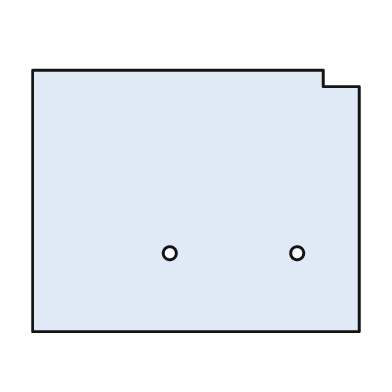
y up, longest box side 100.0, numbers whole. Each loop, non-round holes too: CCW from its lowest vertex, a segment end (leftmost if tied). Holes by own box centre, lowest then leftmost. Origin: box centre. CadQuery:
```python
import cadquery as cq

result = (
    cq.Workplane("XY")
    .moveTo(-50.0, -40.0)
    .lineTo(50.0, -40.0)
    .lineTo(50.0, 35.0)
    .lineTo(39.0, 35.0)
    .lineTo(39.0, 40.0)
    .lineTo(-50.0, 40.0)
    .close()
    .moveTo(-8.0, -16.0)
    .circle(2.0)
    .moveTo(31.0, -16.0)
    .circle(2.0)
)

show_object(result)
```